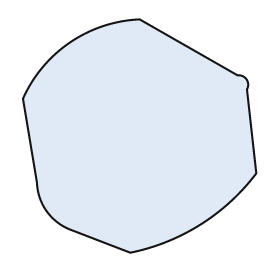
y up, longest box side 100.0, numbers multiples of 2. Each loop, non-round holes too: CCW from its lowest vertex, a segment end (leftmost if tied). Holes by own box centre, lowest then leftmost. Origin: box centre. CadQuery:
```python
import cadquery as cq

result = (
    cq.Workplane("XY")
    .moveTo(-4.0, -50.0)
    .threePointArc((26.0, -38.0), (50.0, -16.0))
    .lineTo(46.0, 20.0)
    .threePointArc((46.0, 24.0), (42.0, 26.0))
    .lineTo(0.0, 50.0)
    .threePointArc((-30.0, 40.0), (-50.0, 16.0))
    .lineTo(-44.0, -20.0)
    .threePointArc((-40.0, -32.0), (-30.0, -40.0))
    .close()
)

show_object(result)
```